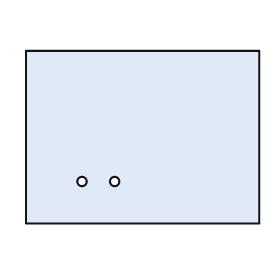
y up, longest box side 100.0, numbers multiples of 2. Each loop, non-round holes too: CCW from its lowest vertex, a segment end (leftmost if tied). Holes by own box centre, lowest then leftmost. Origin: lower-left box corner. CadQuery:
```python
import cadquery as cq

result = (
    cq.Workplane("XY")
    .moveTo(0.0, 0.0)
    .lineTo(100.0, 0.0)
    .lineTo(100.0, 74.0)
    .lineTo(0.0, 74.0)
    .close()
    .moveTo(24.0, 18.0)
    .circle(2.0)
    .moveTo(38.0, 18.0)
    .circle(2.0)
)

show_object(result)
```